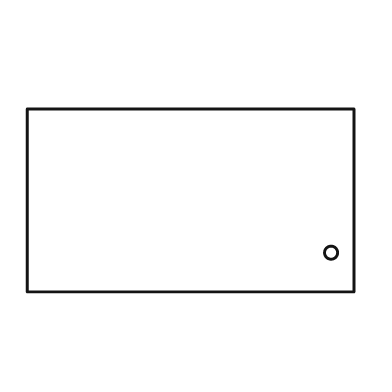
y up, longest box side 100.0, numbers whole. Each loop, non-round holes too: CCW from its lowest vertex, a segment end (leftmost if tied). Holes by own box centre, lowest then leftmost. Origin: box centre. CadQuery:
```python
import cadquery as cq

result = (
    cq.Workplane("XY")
    .moveTo(-50.0, -28.0)
    .lineTo(50.0, -28.0)
    .lineTo(50.0, 28.0)
    .lineTo(-50.0, 28.0)
    .close()
    .moveTo(43.0, -16.0)
    .circle(2.0)
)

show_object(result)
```